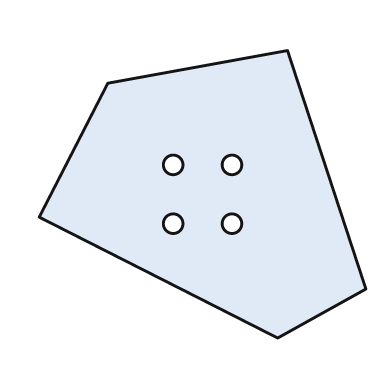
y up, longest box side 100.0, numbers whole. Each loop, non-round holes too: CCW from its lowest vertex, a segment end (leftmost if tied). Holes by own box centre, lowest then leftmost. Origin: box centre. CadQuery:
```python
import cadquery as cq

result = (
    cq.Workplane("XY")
    .moveTo(23.0, -44.0)
    .lineTo(50.0, -29.0)
    .lineTo(26.0, 44.0)
    .lineTo(-29.0, 34.0)
    .lineTo(-50.0, -7.0)
    .close()
    .moveTo(-9.0, -9.0)
    .circle(3.0)
    .moveTo(9.0, -9.0)
    .circle(3.0)
    .moveTo(-9.0, 9.0)
    .circle(3.0)
    .moveTo(9.0, 9.0)
    .circle(3.0)
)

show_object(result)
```